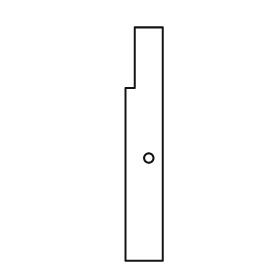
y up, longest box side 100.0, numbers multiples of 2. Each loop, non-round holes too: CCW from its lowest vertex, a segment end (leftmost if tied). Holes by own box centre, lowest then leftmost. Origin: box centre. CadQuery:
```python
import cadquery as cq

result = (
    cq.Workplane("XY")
    .moveTo(-8.0, -50.0)
    .lineTo(8.0, -50.0)
    .lineTo(8.0, 50.0)
    .lineTo(-4.0, 50.0)
    .lineTo(-4.0, 24.0)
    .lineTo(-8.0, 24.0)
    .close()
    .moveTo(2.0, -6.0)
    .circle(2.0)
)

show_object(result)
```